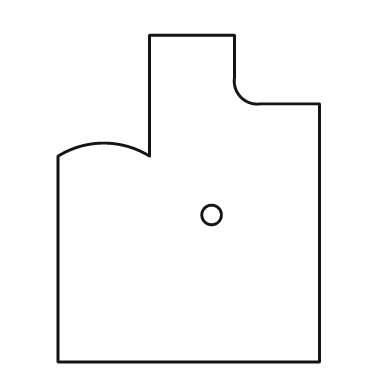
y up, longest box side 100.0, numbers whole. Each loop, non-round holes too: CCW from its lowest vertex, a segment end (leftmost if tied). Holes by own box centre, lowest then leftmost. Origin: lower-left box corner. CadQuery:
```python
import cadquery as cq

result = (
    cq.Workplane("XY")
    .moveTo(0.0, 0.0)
    .lineTo(80.0, 0.0)
    .lineTo(80.0, 79.0)
    .lineTo(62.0, 79.0)
    .threePointArc((56.0, 81.0), (54.0, 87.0))
    .lineTo(54.0, 100.0)
    .lineTo(28.0, 100.0)
    .lineTo(28.0, 63.0)
    .threePointArc((14.0, 67.0), (0.0, 63.0))
    .close()
    .moveTo(47.0, 45.0)
    .circle(3.0)
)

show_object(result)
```